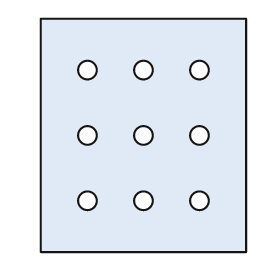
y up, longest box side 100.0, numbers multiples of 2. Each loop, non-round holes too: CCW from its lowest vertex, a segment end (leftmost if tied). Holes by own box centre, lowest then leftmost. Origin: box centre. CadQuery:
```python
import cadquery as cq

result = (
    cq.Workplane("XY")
    .moveTo(-44.0, -50.0)
    .lineTo(44.0, -50.0)
    .lineTo(44.0, 50.0)
    .lineTo(-44.0, 50.0)
    .close()
    .moveTo(-24.0, -28.0)
    .circle(4.0)
    .moveTo(0.0, -28.0)
    .circle(4.0)
    .moveTo(24.0, -28.0)
    .circle(4.0)
    .moveTo(-24.0, 0.0)
    .circle(4.0)
    .moveTo(0.0, 0.0)
    .circle(4.0)
    .moveTo(24.0, 0.0)
    .circle(4.0)
    .moveTo(-24.0, 28.0)
    .circle(4.0)
    .moveTo(0.0, 28.0)
    .circle(4.0)
    .moveTo(24.0, 28.0)
    .circle(4.0)
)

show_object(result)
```